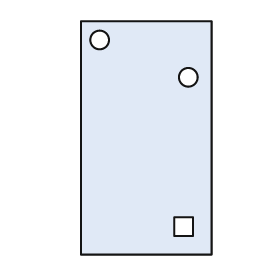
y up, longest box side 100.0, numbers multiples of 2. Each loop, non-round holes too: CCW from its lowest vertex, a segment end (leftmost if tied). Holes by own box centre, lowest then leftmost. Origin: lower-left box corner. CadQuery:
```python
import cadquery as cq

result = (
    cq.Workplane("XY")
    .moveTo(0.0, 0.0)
    .lineTo(56.0, 0.0)
    .lineTo(56.0, 100.0)
    .lineTo(0.0, 100.0)
    .close()
    .moveTo(40.0, 8.0)
    .lineTo(48.0, 8.0)
    .lineTo(48.0, 16.0)
    .lineTo(40.0, 16.0)
    .close()
    .moveTo(46.0, 76.0)
    .circle(4.0)
    .moveTo(8.0, 92.0)
    .circle(4.0)
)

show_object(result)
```